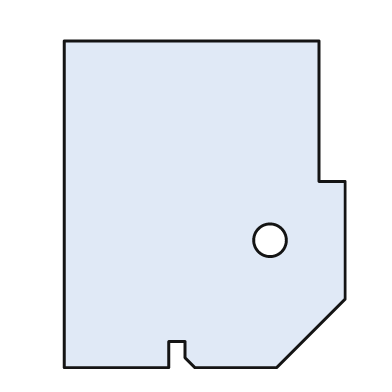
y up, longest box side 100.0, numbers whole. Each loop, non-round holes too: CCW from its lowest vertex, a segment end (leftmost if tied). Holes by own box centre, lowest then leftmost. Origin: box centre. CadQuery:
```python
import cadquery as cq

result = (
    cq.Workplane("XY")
    .moveTo(-43.0, -50.0)
    .lineTo(-11.0, -50.0)
    .lineTo(-11.0, -42.0)
    .lineTo(-6.0, -42.0)
    .lineTo(-6.0, -47.0)
    .lineTo(-3.0, -50.0)
    .lineTo(22.0, -50.0)
    .lineTo(43.0, -29.0)
    .lineTo(43.0, 7.0)
    .lineTo(35.0, 7.0)
    .lineTo(35.0, 50.0)
    .lineTo(-43.0, 50.0)
    .close()
    .moveTo(20.0, -11.0)
    .circle(5.0)
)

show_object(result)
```